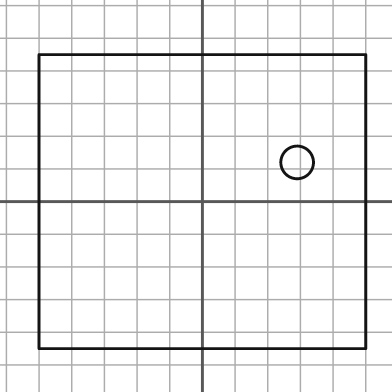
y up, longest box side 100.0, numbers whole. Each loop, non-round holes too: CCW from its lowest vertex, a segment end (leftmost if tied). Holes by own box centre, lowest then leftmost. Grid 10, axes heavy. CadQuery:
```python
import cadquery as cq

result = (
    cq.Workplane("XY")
    .moveTo(-50.0, -45.0)
    .lineTo(50.0, -45.0)
    .lineTo(50.0, 45.0)
    .lineTo(-50.0, 45.0)
    .close()
    .moveTo(29.0, 12.0)
    .circle(5.0)
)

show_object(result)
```